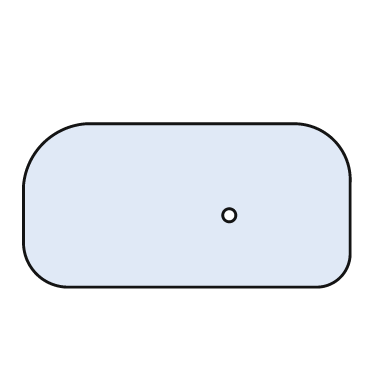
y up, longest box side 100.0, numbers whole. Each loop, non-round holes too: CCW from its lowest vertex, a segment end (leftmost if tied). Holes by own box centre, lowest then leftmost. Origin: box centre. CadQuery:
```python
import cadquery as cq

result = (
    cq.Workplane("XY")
    .moveTo(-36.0, -25.0)
    .lineTo(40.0, -25.0)
    .threePointArc((47.0, -22.0), (50.0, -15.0))
    .lineTo(50.0, 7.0)
    .threePointArc((45.0, 20.0), (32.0, 25.0))
    .lineTo(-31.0, 25.0)
    .threePointArc((-44.0, 19.0), (-50.0, 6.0))
    .lineTo(-50.0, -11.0)
    .threePointArc((-46.0, -21.0), (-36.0, -25.0))
    .close()
    .moveTo(13.0, -3.0)
    .circle(2.0)
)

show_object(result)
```